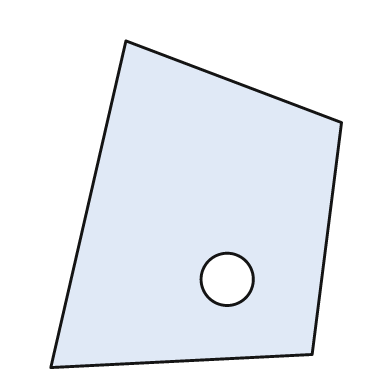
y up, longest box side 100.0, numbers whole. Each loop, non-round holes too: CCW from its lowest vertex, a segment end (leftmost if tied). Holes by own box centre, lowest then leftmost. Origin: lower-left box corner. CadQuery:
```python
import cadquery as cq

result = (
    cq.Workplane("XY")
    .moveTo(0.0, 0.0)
    .lineTo(80.0, 4.0)
    .lineTo(89.0, 75.0)
    .lineTo(23.0, 100.0)
    .close()
    .moveTo(54.0, 27.0)
    .circle(8.0)
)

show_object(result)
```